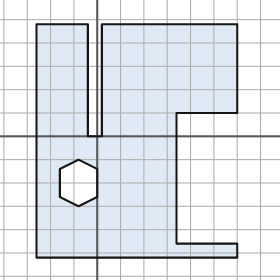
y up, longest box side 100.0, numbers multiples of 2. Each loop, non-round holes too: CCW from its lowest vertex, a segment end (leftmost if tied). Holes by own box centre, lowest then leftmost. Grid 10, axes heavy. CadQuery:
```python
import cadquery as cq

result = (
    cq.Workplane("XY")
    .moveTo(-26.0, -52.0)
    .lineTo(60.0, -52.0)
    .lineTo(60.0, -46.0)
    .lineTo(34.0, -46.0)
    .lineTo(34.0, 10.0)
    .lineTo(60.0, 10.0)
    .lineTo(60.0, 48.0)
    .lineTo(2.0, 48.0)
    .lineTo(2.0, 0.0)
    .lineTo(-4.0, 0.0)
    .lineTo(-4.0, 48.0)
    .lineTo(-26.0, 48.0)
    .close()
    .moveTo(-8.0, -30.0)
    .lineTo(0.0, -26.0)
    .lineTo(0.0, -14.0)
    .lineTo(-8.0, -10.0)
    .lineTo(-16.0, -14.0)
    .lineTo(-16.0, -26.0)
    .close()
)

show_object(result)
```